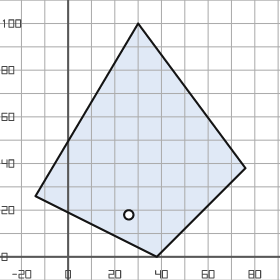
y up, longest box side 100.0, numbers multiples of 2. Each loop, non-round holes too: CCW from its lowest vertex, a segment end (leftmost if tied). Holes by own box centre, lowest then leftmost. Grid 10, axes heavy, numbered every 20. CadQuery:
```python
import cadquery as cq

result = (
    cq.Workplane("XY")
    .moveTo(38.0, 0.0)
    .lineTo(76.0, 38.0)
    .lineTo(30.0, 100.0)
    .lineTo(-14.0, 26.0)
    .close()
    .moveTo(26.0, 18.0)
    .circle(2.0)
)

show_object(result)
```